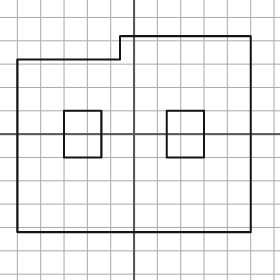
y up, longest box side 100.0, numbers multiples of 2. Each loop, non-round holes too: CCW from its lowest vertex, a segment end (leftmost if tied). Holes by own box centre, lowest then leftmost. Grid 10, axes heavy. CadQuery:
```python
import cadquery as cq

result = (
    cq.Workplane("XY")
    .moveTo(-50.0, -42.0)
    .lineTo(50.0, -42.0)
    .lineTo(50.0, 42.0)
    .lineTo(-6.0, 42.0)
    .lineTo(-6.0, 32.0)
    .lineTo(-50.0, 32.0)
    .close()
    .moveTo(-30.0, -10.0)
    .lineTo(-14.0, -10.0)
    .lineTo(-14.0, 10.0)
    .lineTo(-30.0, 10.0)
    .close()
    .moveTo(14.0, -10.0)
    .lineTo(30.0, -10.0)
    .lineTo(30.0, 10.0)
    .lineTo(14.0, 10.0)
    .close()
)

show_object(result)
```